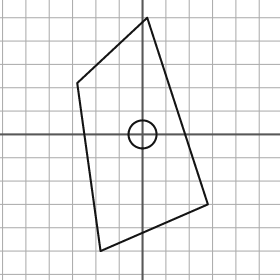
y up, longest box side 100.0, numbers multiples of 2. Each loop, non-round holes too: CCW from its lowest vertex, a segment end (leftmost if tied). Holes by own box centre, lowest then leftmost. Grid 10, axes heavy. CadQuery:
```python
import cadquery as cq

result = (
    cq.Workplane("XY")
    .moveTo(-18.0, -50.0)
    .lineTo(28.0, -30.0)
    .lineTo(2.0, 50.0)
    .lineTo(-28.0, 22.0)
    .close()
    .moveTo(0.0, 0.0)
    .circle(6.0)
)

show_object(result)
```